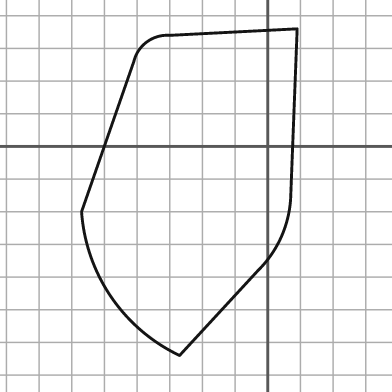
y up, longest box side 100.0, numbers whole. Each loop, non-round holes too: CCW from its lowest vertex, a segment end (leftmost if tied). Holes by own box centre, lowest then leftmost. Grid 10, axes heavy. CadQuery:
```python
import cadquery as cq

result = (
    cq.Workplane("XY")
    .moveTo(-27.0, -64.0)
    .lineTo(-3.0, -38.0)
    .threePointArc((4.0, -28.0), (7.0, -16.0))
    .lineTo(9.0, 36.0)
    .lineTo(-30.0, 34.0)
    .threePointArc((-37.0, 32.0), (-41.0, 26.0))
    .lineTo(-57.0, -20.0)
    .threePointArc((-48.0, -46.0), (-27.0, -64.0))
    .close()
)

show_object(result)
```